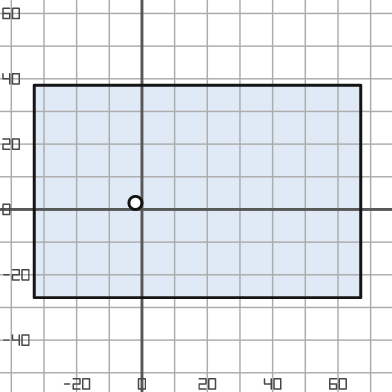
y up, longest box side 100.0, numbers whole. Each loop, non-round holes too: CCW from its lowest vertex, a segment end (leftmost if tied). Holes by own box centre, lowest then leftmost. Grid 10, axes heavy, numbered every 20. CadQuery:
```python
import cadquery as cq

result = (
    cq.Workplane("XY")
    .moveTo(-33.0, -27.0)
    .lineTo(67.0, -27.0)
    .lineTo(67.0, 38.0)
    .lineTo(-33.0, 38.0)
    .close()
    .moveTo(-2.0, 2.0)
    .circle(2.0)
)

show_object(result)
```